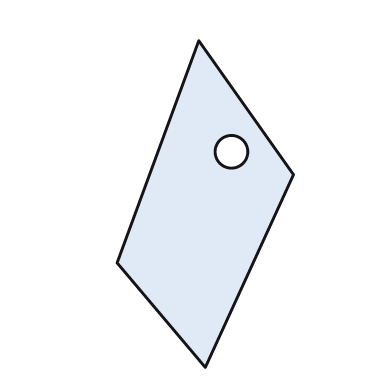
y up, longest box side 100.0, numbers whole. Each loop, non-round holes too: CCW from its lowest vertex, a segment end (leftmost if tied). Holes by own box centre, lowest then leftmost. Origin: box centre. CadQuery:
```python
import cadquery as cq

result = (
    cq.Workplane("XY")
    .moveTo(0.0, -50.0)
    .lineTo(27.0, 9.0)
    .lineTo(-2.0, 50.0)
    .lineTo(-27.0, -18.0)
    .close()
    .moveTo(8.0, 16.0)
    .circle(5.0)
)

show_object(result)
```